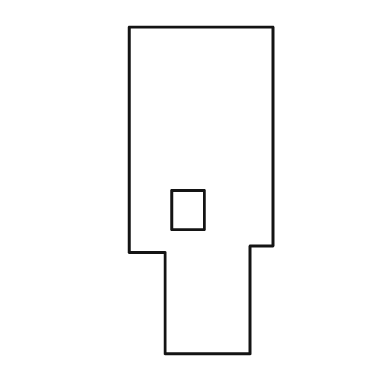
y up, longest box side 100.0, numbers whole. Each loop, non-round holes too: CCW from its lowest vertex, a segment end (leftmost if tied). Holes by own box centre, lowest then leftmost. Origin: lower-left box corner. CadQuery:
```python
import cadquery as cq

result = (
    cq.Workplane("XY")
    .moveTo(11.0, 0.0)
    .lineTo(37.0, 0.0)
    .lineTo(37.0, 33.0)
    .lineTo(44.0, 33.0)
    .lineTo(44.0, 100.0)
    .lineTo(0.0, 100.0)
    .lineTo(0.0, 31.0)
    .lineTo(11.0, 31.0)
    .close()
    .moveTo(13.0, 38.0)
    .lineTo(23.0, 38.0)
    .lineTo(23.0, 50.0)
    .lineTo(13.0, 50.0)
    .close()
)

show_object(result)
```